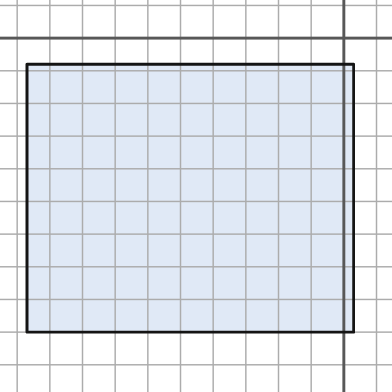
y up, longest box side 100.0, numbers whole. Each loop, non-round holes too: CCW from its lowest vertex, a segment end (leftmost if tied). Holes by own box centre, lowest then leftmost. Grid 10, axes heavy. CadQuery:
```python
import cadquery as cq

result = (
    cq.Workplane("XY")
    .moveTo(-97.0, -90.0)
    .lineTo(3.0, -90.0)
    .lineTo(3.0, -8.0)
    .lineTo(-97.0, -8.0)
    .close()
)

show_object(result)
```